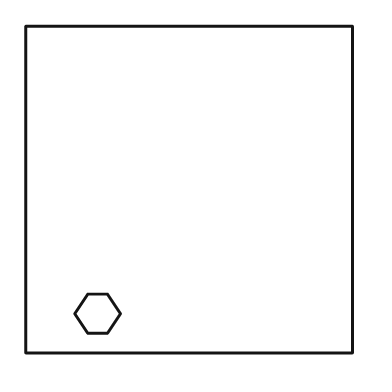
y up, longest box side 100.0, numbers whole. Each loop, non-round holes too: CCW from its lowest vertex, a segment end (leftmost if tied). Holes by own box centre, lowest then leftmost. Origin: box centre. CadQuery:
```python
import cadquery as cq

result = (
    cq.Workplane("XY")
    .moveTo(-50.0, -50.0)
    .lineTo(50.0, -50.0)
    .lineTo(50.0, 50.0)
    .lineTo(-50.0, 50.0)
    .close()
    .moveTo(-31.0, -44.0)
    .lineTo(-25.0, -44.0)
    .lineTo(-21.0, -38.0)
    .lineTo(-25.0, -32.0)
    .lineTo(-31.0, -32.0)
    .lineTo(-35.0, -38.0)
    .close()
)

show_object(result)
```